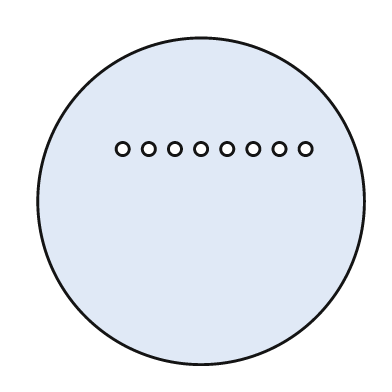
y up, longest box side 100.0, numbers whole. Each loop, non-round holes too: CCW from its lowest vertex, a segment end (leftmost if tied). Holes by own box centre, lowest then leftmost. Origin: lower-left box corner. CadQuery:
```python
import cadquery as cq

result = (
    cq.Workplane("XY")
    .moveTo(50.0, 50.0)
    .circle(50.0)
    .moveTo(26.0, 66.0)
    .circle(2.0)
    .moveTo(34.0, 66.0)
    .circle(2.0)
    .moveTo(42.0, 66.0)
    .circle(2.0)
    .moveTo(50.0, 66.0)
    .circle(2.0)
    .moveTo(58.0, 66.0)
    .circle(2.0)
    .moveTo(66.0, 66.0)
    .circle(2.0)
    .moveTo(74.0, 66.0)
    .circle(2.0)
    .moveTo(82.0, 66.0)
    .circle(2.0)
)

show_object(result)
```